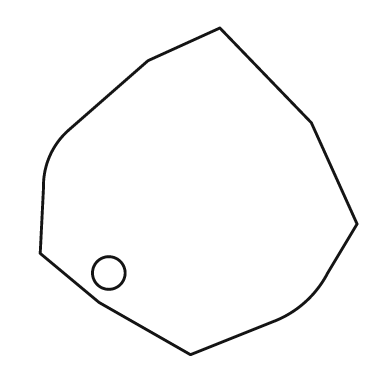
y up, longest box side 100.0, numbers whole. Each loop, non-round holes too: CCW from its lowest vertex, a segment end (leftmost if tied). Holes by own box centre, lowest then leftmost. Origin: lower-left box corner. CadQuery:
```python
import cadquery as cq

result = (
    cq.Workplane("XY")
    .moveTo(46.0, 0.0)
    .lineTo(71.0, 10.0)
    .threePointArc((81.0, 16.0), (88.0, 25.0))
    .lineTo(97.0, 40.0)
    .lineTo(83.0, 71.0)
    .lineTo(55.0, 100.0)
    .lineTo(33.0, 90.0)
    .lineTo(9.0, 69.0)
    .threePointArc((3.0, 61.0), (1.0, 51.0))
    .lineTo(0.0, 31.0)
    .lineTo(18.0, 16.0)
    .close()
    .moveTo(21.0, 25.0)
    .circle(5.0)
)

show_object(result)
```